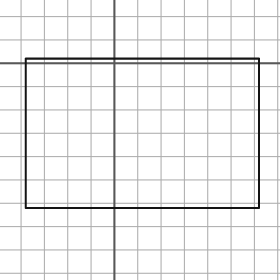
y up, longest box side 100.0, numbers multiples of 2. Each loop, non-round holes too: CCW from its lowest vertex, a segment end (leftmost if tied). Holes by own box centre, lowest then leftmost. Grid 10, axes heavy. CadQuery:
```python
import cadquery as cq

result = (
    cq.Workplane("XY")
    .moveTo(-38.0, -62.0)
    .lineTo(62.0, -62.0)
    .lineTo(62.0, 2.0)
    .lineTo(-38.0, 2.0)
    .close()
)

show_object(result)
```